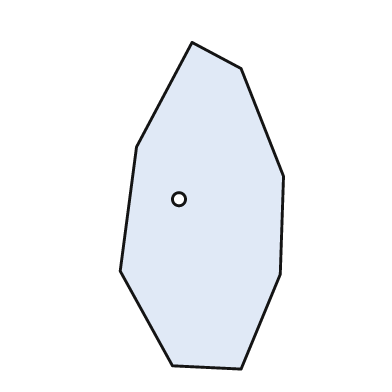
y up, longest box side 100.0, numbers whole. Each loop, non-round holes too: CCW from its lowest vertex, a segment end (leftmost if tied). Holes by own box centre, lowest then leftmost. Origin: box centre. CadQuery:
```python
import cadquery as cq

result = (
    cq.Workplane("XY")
    .moveTo(12.0, -50.0)
    .lineTo(24.0, -21.0)
    .lineTo(25.0, 9.0)
    .lineTo(12.0, 42.0)
    .lineTo(-3.0, 50.0)
    .lineTo(-20.0, 18.0)
    .lineTo(-25.0, -20.0)
    .lineTo(-9.0, -49.0)
    .close()
    .moveTo(-7.0, 2.0)
    .circle(2.0)
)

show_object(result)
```